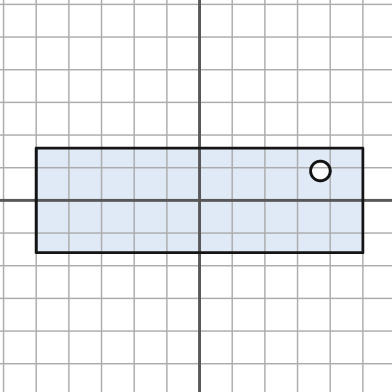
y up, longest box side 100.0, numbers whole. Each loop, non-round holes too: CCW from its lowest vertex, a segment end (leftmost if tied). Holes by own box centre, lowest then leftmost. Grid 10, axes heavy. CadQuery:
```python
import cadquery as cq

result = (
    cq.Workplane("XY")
    .moveTo(-50.0, -16.0)
    .lineTo(50.0, -16.0)
    .lineTo(50.0, 16.0)
    .lineTo(-50.0, 16.0)
    .close()
    .moveTo(37.0, 9.0)
    .circle(3.0)
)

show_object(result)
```